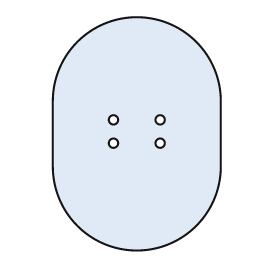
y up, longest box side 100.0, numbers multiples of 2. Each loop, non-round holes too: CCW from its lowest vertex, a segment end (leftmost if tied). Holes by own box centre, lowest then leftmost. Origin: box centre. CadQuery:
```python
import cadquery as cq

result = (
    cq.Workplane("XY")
    .moveTo(-36.0, -14.0)
    .threePointArc((0.0, -50.0), (36.0, -14.0))
    .lineTo(36.0, 14.0)
    .threePointArc((0.0, 50.0), (-36.0, 14.0))
    .close()
    .moveTo(-10.0, -4.0)
    .circle(2.0)
    .moveTo(10.0, -4.0)
    .circle(2.0)
    .moveTo(-10.0, 6.0)
    .circle(2.0)
    .moveTo(10.0, 6.0)
    .circle(2.0)
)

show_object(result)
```